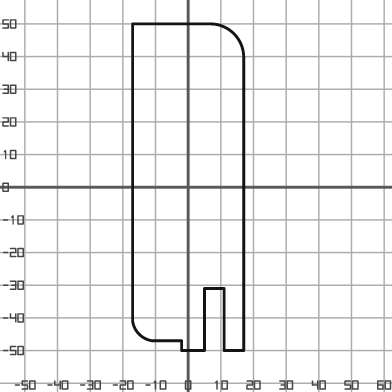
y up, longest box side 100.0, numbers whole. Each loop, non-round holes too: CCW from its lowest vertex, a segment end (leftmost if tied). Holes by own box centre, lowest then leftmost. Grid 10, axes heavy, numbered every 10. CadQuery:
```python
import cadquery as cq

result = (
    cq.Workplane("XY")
    .moveTo(-2.0, -50.0)
    .lineTo(5.0, -50.0)
    .lineTo(5.0, -31.0)
    .lineTo(11.0, -31.0)
    .lineTo(11.0, -50.0)
    .lineTo(17.0, -50.0)
    .lineTo(17.0, 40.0)
    .threePointArc((14.0, 47.0), (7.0, 50.0))
    .lineTo(-17.0, 50.0)
    .lineTo(-17.0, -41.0)
    .threePointArc((-15.0, -45.0), (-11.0, -47.0))
    .lineTo(-2.0, -47.0)
    .close()
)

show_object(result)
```